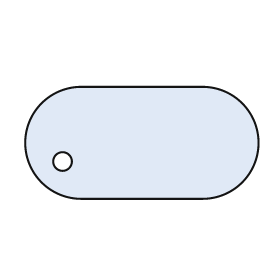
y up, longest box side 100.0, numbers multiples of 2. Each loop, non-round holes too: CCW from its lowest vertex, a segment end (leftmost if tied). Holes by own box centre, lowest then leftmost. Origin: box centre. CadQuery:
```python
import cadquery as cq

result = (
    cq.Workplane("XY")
    .moveTo(-26.0, -24.0)
    .lineTo(26.0, -24.0)
    .threePointArc((50.0, 0.0), (26.0, 24.0))
    .lineTo(-26.0, 24.0)
    .threePointArc((-50.0, 0.0), (-26.0, -24.0))
    .close()
    .moveTo(-34.0, -8.0)
    .circle(4.0)
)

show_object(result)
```